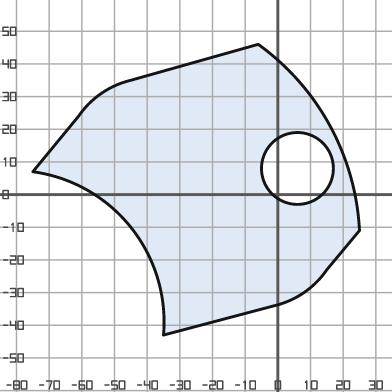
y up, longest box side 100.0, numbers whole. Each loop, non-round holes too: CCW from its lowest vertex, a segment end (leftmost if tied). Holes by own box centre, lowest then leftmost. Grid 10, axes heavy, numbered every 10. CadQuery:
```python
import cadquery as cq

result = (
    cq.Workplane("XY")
    .moveTo(-35.0, -43.0)
    .lineTo(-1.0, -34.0)
    .threePointArc((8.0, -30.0), (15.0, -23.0))
    .lineTo(25.0, -11.0)
    .threePointArc((16.0, 21.0), (-6.0, 46.0))
    .lineTo(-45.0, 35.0)
    .threePointArc((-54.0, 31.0), (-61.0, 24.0))
    .lineTo(-75.0, 7.0)
    .threePointArc((-45.0, -10.0), (-35.0, -43.0))
    .close()
    .moveTo(6.0, 8.0)
    .circle(11.0)
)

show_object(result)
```